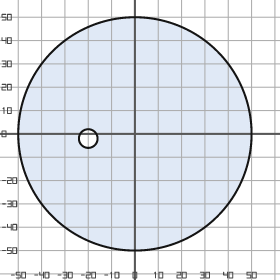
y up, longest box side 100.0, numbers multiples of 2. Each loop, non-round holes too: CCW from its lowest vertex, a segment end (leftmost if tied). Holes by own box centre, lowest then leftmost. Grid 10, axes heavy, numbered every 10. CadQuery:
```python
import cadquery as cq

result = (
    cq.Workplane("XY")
    .moveTo(0.0, 0.0)
    .circle(50.0)
    .moveTo(-20.0, -2.0)
    .circle(4.0)
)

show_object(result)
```